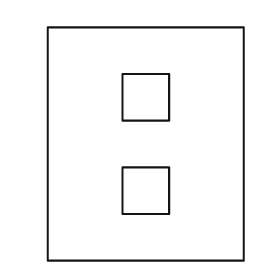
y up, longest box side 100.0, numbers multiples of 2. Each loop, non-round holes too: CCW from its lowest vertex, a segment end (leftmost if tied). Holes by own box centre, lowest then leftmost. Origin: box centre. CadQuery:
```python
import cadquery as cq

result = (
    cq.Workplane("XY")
    .moveTo(-42.0, -50.0)
    .lineTo(42.0, -50.0)
    .lineTo(42.0, 50.0)
    .lineTo(-42.0, 50.0)
    .close()
    .moveTo(-10.0, -30.0)
    .lineTo(10.0, -30.0)
    .lineTo(10.0, -10.0)
    .lineTo(-10.0, -10.0)
    .close()
    .moveTo(-10.0, 10.0)
    .lineTo(10.0, 10.0)
    .lineTo(10.0, 30.0)
    .lineTo(-10.0, 30.0)
    .close()
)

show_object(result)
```